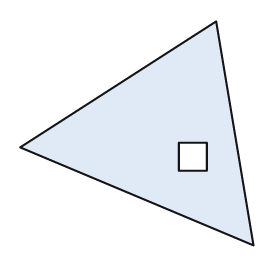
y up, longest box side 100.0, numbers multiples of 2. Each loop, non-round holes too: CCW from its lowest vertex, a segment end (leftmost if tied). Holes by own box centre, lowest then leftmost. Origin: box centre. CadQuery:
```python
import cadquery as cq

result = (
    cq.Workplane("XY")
    .moveTo(50.0, -48.0)
    .lineTo(34.0, 48.0)
    .lineTo(-50.0, -6.0)
    .close()
    .moveTo(18.0, -16.0)
    .lineTo(30.0, -16.0)
    .lineTo(30.0, -4.0)
    .lineTo(18.0, -4.0)
    .close()
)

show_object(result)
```